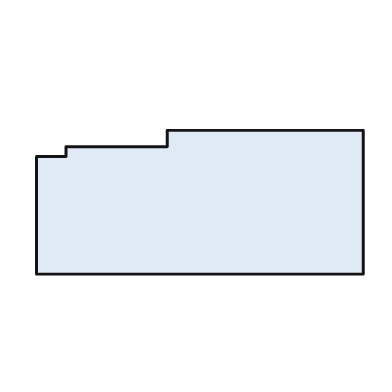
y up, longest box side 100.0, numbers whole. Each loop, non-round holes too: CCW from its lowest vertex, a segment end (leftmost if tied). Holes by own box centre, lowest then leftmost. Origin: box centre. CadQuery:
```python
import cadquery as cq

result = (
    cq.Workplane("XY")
    .moveTo(-50.0, -22.0)
    .lineTo(50.0, -22.0)
    .lineTo(50.0, 22.0)
    .lineTo(-10.0, 22.0)
    .lineTo(-10.0, 17.0)
    .lineTo(-41.0, 17.0)
    .lineTo(-41.0, 14.0)
    .lineTo(-50.0, 14.0)
    .close()
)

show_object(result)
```